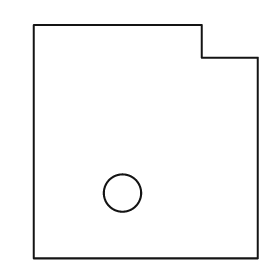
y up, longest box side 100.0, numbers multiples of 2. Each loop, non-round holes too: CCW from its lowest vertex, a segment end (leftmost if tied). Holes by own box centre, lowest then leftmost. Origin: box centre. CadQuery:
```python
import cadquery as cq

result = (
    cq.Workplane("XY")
    .moveTo(-48.0, -50.0)
    .lineTo(48.0, -50.0)
    .lineTo(48.0, 36.0)
    .lineTo(24.0, 36.0)
    .lineTo(24.0, 50.0)
    .lineTo(-48.0, 50.0)
    .close()
    .moveTo(-10.0, -22.0)
    .circle(8.0)
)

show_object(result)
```